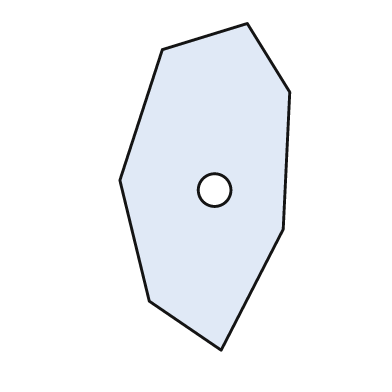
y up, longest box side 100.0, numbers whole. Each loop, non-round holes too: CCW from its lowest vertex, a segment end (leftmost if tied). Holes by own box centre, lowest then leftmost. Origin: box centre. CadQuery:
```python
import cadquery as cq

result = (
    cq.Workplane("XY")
    .moveTo(5.0, -50.0)
    .lineTo(24.0, -13.0)
    .lineTo(26.0, 29.0)
    .lineTo(13.0, 50.0)
    .lineTo(-13.0, 42.0)
    .lineTo(-26.0, 2.0)
    .lineTo(-17.0, -35.0)
    .close()
    .moveTo(3.0, -1.0)
    .circle(5.0)
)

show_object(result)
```